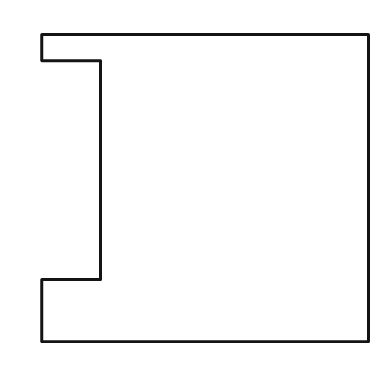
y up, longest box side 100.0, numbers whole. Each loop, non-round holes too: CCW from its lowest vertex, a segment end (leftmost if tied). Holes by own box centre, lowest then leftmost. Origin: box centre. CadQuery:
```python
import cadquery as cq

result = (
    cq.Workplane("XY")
    .moveTo(-50.0, -47.0)
    .lineTo(50.0, -47.0)
    .lineTo(50.0, 47.0)
    .lineTo(-50.0, 47.0)
    .lineTo(-50.0, 39.0)
    .lineTo(-32.0, 39.0)
    .lineTo(-32.0, -28.0)
    .lineTo(-50.0, -28.0)
    .close()
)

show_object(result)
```